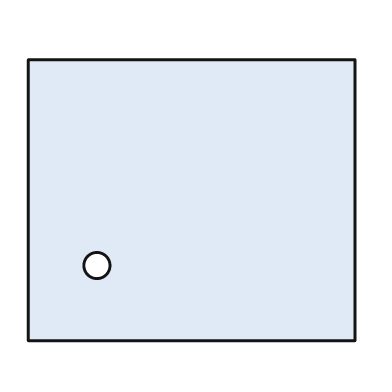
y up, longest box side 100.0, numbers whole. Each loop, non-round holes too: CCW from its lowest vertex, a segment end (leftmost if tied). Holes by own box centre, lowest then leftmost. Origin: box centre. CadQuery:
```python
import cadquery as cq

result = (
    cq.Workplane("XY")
    .moveTo(-50.0, -43.0)
    .lineTo(50.0, -43.0)
    .lineTo(50.0, 43.0)
    .lineTo(-50.0, 43.0)
    .close()
    .moveTo(-29.0, -20.0)
    .circle(4.0)
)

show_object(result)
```